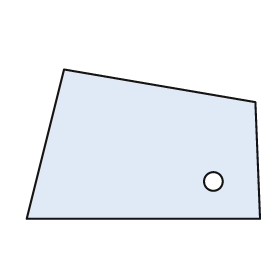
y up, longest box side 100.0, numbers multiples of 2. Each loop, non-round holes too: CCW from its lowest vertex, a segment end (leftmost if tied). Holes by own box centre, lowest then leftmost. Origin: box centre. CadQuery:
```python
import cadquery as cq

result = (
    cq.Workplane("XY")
    .moveTo(-50.0, -32.0)
    .lineTo(50.0, -32.0)
    .lineTo(48.0, 18.0)
    .lineTo(-34.0, 32.0)
    .close()
    .moveTo(30.0, -16.0)
    .circle(4.0)
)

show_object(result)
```